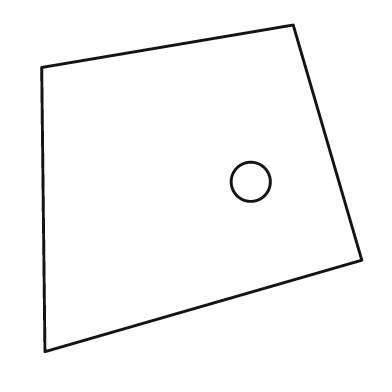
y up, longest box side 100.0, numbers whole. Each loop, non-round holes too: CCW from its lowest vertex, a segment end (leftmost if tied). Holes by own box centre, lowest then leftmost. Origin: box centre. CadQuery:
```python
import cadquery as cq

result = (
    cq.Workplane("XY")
    .moveTo(-48.0, -50.0)
    .lineTo(49.0, -22.0)
    .lineTo(28.0, 50.0)
    .lineTo(-49.0, 37.0)
    .close()
    .moveTo(15.0, 2.0)
    .circle(6.0)
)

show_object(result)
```